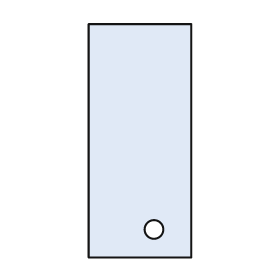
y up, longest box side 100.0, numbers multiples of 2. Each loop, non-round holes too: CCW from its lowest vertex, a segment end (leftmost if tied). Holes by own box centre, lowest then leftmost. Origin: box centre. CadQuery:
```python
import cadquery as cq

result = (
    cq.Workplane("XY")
    .moveTo(-22.0, -50.0)
    .lineTo(22.0, -50.0)
    .lineTo(22.0, 50.0)
    .lineTo(-22.0, 50.0)
    .close()
    .moveTo(6.0, -38.0)
    .circle(4.0)
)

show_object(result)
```